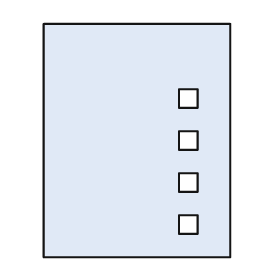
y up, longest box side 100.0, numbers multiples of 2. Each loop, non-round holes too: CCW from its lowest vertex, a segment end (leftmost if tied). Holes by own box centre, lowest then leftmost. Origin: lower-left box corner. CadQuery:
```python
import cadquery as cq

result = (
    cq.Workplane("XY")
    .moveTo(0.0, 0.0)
    .lineTo(80.0, 0.0)
    .lineTo(80.0, 100.0)
    .lineTo(0.0, 100.0)
    .close()
    .moveTo(58.0, 10.0)
    .lineTo(66.0, 10.0)
    .lineTo(66.0, 18.0)
    .lineTo(58.0, 18.0)
    .close()
    .moveTo(58.0, 28.0)
    .lineTo(66.0, 28.0)
    .lineTo(66.0, 36.0)
    .lineTo(58.0, 36.0)
    .close()
    .moveTo(58.0, 46.0)
    .lineTo(66.0, 46.0)
    .lineTo(66.0, 54.0)
    .lineTo(58.0, 54.0)
    .close()
    .moveTo(58.0, 64.0)
    .lineTo(66.0, 64.0)
    .lineTo(66.0, 72.0)
    .lineTo(58.0, 72.0)
    .close()
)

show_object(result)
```